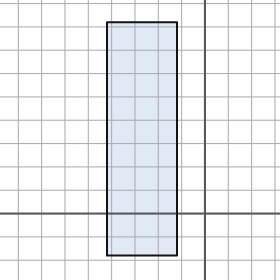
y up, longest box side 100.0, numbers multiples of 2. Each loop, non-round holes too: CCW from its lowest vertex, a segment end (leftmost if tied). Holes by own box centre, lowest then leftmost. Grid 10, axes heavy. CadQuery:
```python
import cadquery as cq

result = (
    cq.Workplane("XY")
    .moveTo(-42.0, -18.0)
    .lineTo(-12.0, -18.0)
    .lineTo(-12.0, 82.0)
    .lineTo(-42.0, 82.0)
    .close()
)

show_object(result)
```